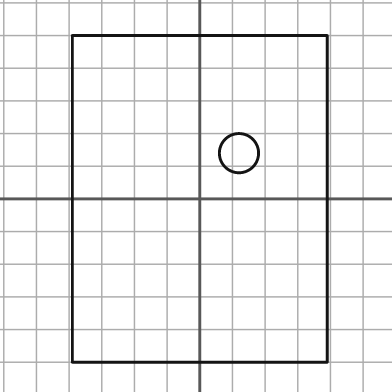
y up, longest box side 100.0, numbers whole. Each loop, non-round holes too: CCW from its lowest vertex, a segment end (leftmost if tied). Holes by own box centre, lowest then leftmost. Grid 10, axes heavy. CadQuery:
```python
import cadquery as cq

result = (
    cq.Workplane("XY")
    .moveTo(-39.0, -50.0)
    .lineTo(39.0, -50.0)
    .lineTo(39.0, 50.0)
    .lineTo(-39.0, 50.0)
    .close()
    .moveTo(12.0, 14.0)
    .circle(6.0)
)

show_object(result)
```